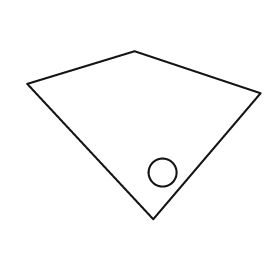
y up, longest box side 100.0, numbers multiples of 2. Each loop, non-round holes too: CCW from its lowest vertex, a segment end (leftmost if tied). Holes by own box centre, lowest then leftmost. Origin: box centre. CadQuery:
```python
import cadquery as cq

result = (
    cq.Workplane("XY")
    .moveTo(4.0, -36.0)
    .lineTo(50.0, 18.0)
    .lineTo(-4.0, 36.0)
    .lineTo(-50.0, 22.0)
    .close()
    .moveTo(8.0, -16.0)
    .circle(6.0)
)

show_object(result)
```